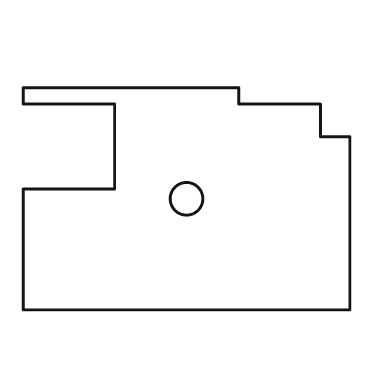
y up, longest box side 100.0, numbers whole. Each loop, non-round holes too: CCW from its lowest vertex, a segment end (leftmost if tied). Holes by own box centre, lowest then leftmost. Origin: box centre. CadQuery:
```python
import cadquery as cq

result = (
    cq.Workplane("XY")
    .moveTo(-50.0, -34.0)
    .lineTo(50.0, -34.0)
    .lineTo(50.0, 19.0)
    .lineTo(41.0, 19.0)
    .lineTo(41.0, 29.0)
    .lineTo(16.0, 29.0)
    .lineTo(16.0, 34.0)
    .lineTo(-50.0, 34.0)
    .lineTo(-50.0, 29.0)
    .lineTo(-22.0, 29.0)
    .lineTo(-22.0, 3.0)
    .lineTo(-50.0, 3.0)
    .close()
    .moveTo(0.0, 0.0)
    .circle(5.0)
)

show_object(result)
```